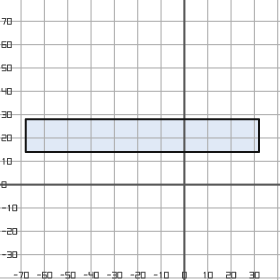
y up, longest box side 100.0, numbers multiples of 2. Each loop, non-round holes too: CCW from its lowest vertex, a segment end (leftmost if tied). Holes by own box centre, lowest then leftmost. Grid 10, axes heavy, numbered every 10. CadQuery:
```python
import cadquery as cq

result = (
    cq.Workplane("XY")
    .moveTo(-68.0, 14.0)
    .lineTo(32.0, 14.0)
    .lineTo(32.0, 28.0)
    .lineTo(-68.0, 28.0)
    .close()
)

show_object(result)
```